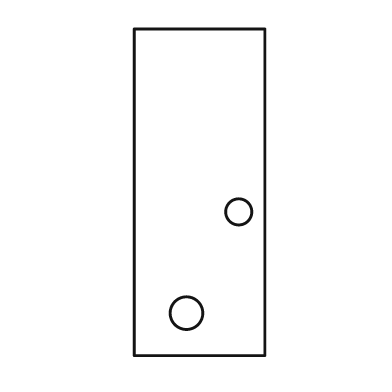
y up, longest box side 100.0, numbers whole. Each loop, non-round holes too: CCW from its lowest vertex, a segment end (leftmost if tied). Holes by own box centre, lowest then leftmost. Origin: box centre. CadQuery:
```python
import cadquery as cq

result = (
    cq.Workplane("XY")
    .moveTo(-20.0, -50.0)
    .lineTo(20.0, -50.0)
    .lineTo(20.0, 50.0)
    .lineTo(-20.0, 50.0)
    .close()
    .moveTo(-4.0, -37.0)
    .circle(5.0)
    .moveTo(12.0, -6.0)
    .circle(4.0)
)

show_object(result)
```